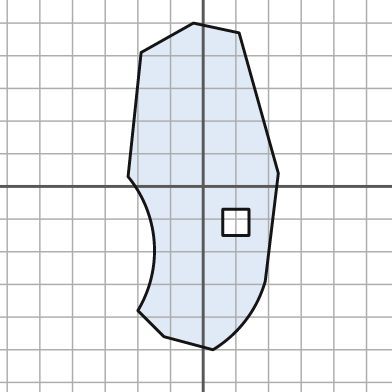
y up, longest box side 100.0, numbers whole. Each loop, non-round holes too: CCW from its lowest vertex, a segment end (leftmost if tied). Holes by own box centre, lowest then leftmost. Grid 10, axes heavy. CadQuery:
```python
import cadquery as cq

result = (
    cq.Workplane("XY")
    .moveTo(3.0, -50.0)
    .threePointArc((13.0, -41.0), (19.0, -29.0))
    .lineTo(23.0, 4.0)
    .lineTo(11.0, 47.0)
    .lineTo(-3.0, 50.0)
    .lineTo(-19.0, 41.0)
    .lineTo(-23.0, 3.0)
    .threePointArc((-15.0, -17.0), (-20.0, -38.0))
    .lineTo(-12.0, -46.0)
    .close()
    .moveTo(6.0, -15.0)
    .lineTo(14.0, -15.0)
    .lineTo(14.0, -7.0)
    .lineTo(6.0, -7.0)
    .close()
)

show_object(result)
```